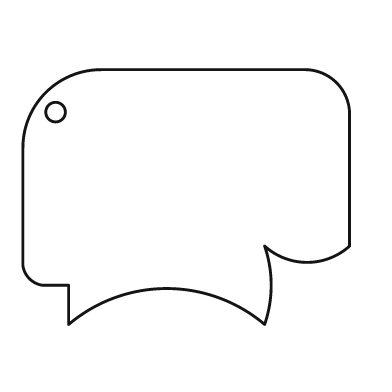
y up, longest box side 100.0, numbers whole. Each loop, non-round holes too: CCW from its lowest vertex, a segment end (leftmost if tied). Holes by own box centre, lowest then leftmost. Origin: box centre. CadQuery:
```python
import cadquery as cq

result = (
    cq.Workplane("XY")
    .moveTo(-36.0, -39.0)
    .threePointArc((-6.0, -28.0), (24.0, -39.0))
    .threePointArc((26.0, -27.0), (24.0, -15.0))
    .threePointArc((37.0, -20.0), (50.0, -15.0))
    .lineTo(50.0, 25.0)
    .threePointArc((46.0, 35.0), (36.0, 39.0))
    .lineTo(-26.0, 39.0)
    .threePointArc((-43.0, 32.0), (-50.0, 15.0))
    .lineTo(-50.0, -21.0)
    .threePointArc((-48.0, -25.0), (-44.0, -27.0))
    .lineTo(-36.0, -27.0)
    .close()
    .moveTo(-40.0, 26.0)
    .circle(3.0)
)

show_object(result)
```